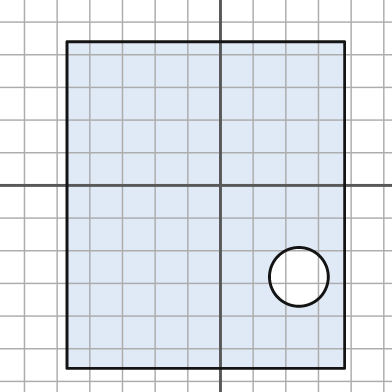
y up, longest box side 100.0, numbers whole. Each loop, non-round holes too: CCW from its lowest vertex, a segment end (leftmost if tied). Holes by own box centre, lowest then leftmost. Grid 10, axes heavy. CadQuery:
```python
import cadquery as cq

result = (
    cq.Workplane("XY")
    .moveTo(-47.0, -56.0)
    .lineTo(38.0, -56.0)
    .lineTo(38.0, 44.0)
    .lineTo(-47.0, 44.0)
    .close()
    .moveTo(24.0, -28.0)
    .circle(9.0)
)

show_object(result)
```